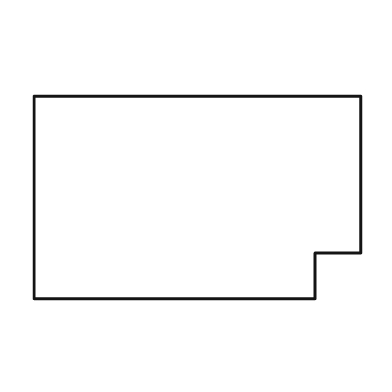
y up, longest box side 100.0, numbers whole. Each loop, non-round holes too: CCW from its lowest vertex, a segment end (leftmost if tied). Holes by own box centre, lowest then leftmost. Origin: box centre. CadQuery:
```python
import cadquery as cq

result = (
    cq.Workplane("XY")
    .moveTo(-50.0, -31.0)
    .lineTo(36.0, -31.0)
    .lineTo(36.0, -17.0)
    .lineTo(50.0, -17.0)
    .lineTo(50.0, 31.0)
    .lineTo(-50.0, 31.0)
    .close()
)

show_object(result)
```